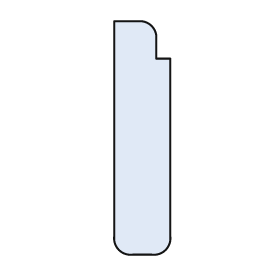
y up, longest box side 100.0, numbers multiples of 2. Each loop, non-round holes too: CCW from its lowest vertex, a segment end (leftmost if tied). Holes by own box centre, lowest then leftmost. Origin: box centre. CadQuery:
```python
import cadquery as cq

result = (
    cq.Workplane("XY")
    .moveTo(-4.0, -50.0)
    .lineTo(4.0, -50.0)
    .threePointArc((10.0, -48.0), (12.0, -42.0))
    .lineTo(12.0, 34.0)
    .lineTo(6.0, 34.0)
    .lineTo(6.0, 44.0)
    .threePointArc((4.0, 48.0), (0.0, 50.0))
    .lineTo(-12.0, 50.0)
    .lineTo(-12.0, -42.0)
    .threePointArc((-10.0, -48.0), (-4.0, -50.0))
    .close()
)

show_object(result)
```